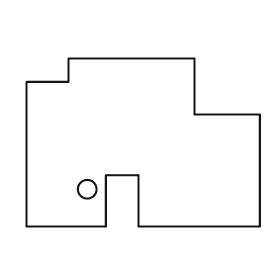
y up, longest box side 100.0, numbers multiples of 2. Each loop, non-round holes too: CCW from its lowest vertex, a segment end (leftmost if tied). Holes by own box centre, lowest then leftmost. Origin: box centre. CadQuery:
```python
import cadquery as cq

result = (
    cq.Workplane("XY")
    .moveTo(-50.0, -36.0)
    .lineTo(-16.0, -36.0)
    .lineTo(-16.0, -14.0)
    .lineTo(-2.0, -14.0)
    .lineTo(-2.0, -36.0)
    .lineTo(50.0, -36.0)
    .lineTo(50.0, 12.0)
    .lineTo(22.0, 12.0)
    .lineTo(22.0, 36.0)
    .lineTo(-32.0, 36.0)
    .lineTo(-32.0, 26.0)
    .lineTo(-50.0, 26.0)
    .close()
    .moveTo(-24.0, -20.0)
    .circle(4.0)
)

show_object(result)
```